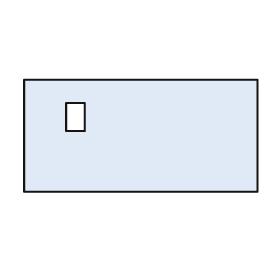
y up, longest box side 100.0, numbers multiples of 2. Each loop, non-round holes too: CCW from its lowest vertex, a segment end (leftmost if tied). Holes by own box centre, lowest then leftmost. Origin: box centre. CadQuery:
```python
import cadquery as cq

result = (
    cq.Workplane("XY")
    .moveTo(-50.0, -24.0)
    .lineTo(50.0, -24.0)
    .lineTo(50.0, 24.0)
    .lineTo(-50.0, 24.0)
    .close()
    .moveTo(-32.0, 2.0)
    .lineTo(-24.0, 2.0)
    .lineTo(-24.0, 14.0)
    .lineTo(-32.0, 14.0)
    .close()
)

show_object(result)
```